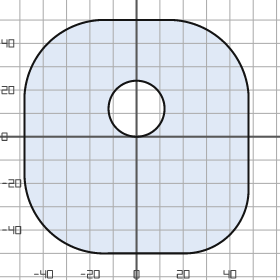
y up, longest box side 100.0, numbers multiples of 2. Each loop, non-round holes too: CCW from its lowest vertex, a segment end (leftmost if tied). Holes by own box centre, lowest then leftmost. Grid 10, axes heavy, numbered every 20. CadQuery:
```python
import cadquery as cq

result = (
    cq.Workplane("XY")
    .moveTo(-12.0, -50.0)
    .lineTo(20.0, -50.0)
    .threePointArc((40.0, -42.0), (48.0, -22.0))
    .lineTo(48.0, 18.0)
    .threePointArc((38.0, 40.0), (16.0, 50.0))
    .lineTo(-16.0, 50.0)
    .threePointArc((-38.0, 40.0), (-48.0, 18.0))
    .lineTo(-48.0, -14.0)
    .threePointArc((-38.0, -40.0), (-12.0, -50.0))
    .close()
    .moveTo(0.0, 12.0)
    .circle(12.0)
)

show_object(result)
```